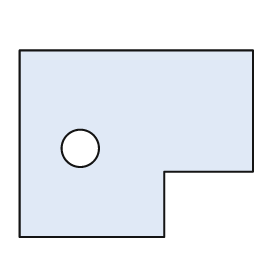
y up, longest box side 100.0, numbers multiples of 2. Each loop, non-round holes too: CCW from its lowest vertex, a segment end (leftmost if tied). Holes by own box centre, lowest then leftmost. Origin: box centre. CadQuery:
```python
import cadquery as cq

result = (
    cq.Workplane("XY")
    .moveTo(-50.0, -40.0)
    .lineTo(12.0, -40.0)
    .lineTo(12.0, -12.0)
    .lineTo(50.0, -12.0)
    .lineTo(50.0, 40.0)
    .lineTo(-50.0, 40.0)
    .close()
    .moveTo(-24.0, -2.0)
    .circle(8.0)
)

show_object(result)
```